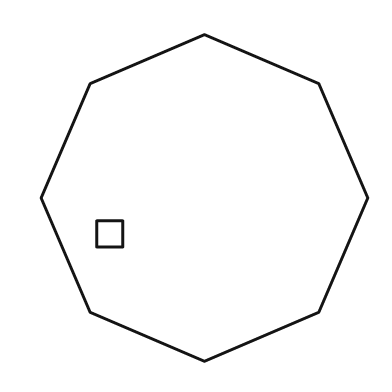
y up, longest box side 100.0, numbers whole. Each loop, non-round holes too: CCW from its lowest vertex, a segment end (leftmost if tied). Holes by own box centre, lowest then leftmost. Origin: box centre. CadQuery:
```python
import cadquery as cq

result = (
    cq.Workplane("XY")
    .moveTo(0.0, -50.0)
    .lineTo(35.0, -35.0)
    .lineTo(50.0, 0.0)
    .lineTo(35.0, 35.0)
    .lineTo(0.0, 50.0)
    .lineTo(-35.0, 35.0)
    .lineTo(-50.0, 0.0)
    .lineTo(-35.0, -35.0)
    .close()
    .moveTo(-33.0, -15.0)
    .lineTo(-25.0, -15.0)
    .lineTo(-25.0, -7.0)
    .lineTo(-33.0, -7.0)
    .close()
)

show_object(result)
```